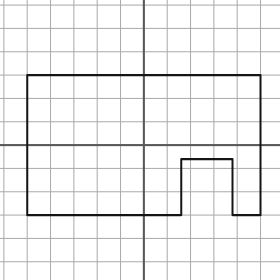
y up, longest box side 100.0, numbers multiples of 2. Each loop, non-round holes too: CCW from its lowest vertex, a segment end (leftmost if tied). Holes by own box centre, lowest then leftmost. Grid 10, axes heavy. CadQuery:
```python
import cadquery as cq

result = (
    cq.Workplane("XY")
    .moveTo(-50.0, -30.0)
    .lineTo(16.0, -30.0)
    .lineTo(16.0, -6.0)
    .lineTo(38.0, -6.0)
    .lineTo(38.0, -30.0)
    .lineTo(50.0, -30.0)
    .lineTo(50.0, 30.0)
    .lineTo(-50.0, 30.0)
    .close()
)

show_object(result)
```